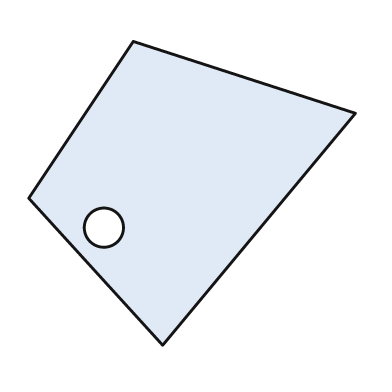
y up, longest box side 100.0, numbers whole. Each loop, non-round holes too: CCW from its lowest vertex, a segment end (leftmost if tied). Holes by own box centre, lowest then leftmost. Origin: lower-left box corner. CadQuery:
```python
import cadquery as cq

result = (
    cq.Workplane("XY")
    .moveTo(41.0, 0.0)
    .lineTo(100.0, 71.0)
    .lineTo(32.0, 93.0)
    .lineTo(0.0, 45.0)
    .close()
    .moveTo(23.0, 36.0)
    .circle(6.0)
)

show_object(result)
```